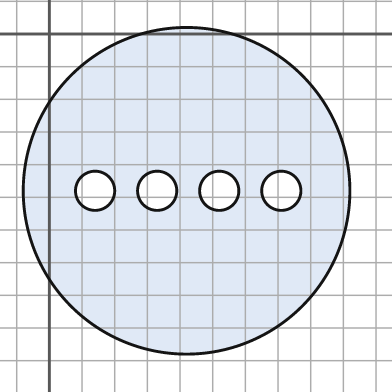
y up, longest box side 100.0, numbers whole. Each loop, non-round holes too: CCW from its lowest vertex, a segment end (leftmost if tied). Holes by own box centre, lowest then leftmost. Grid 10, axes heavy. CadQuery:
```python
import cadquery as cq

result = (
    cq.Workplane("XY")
    .moveTo(42.0, -48.0)
    .circle(50.0)
    .moveTo(14.0, -48.0)
    .circle(6.0)
    .moveTo(33.0, -48.0)
    .circle(6.0)
    .moveTo(52.0, -48.0)
    .circle(6.0)
    .moveTo(71.0, -48.0)
    .circle(6.0)
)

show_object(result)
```